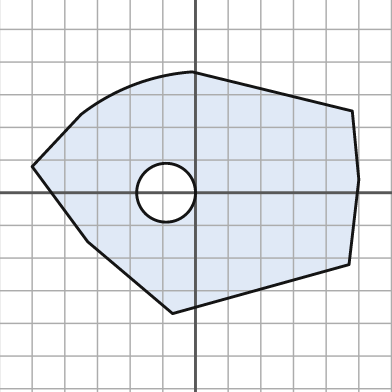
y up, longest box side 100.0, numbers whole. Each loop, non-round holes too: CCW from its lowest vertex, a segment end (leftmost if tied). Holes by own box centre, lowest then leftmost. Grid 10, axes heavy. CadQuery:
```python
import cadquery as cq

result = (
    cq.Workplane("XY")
    .moveTo(-7.0, -37.0)
    .lineTo(47.0, -22.0)
    .lineTo(50.0, 4.0)
    .lineTo(48.0, 25.0)
    .lineTo(-1.0, 37.0)
    .threePointArc((-19.0, 33.0), (-35.0, 24.0))
    .lineTo(-50.0, 8.0)
    .lineTo(-33.0, -15.0)
    .close()
    .moveTo(-9.0, 0.0)
    .circle(9.0)
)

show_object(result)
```